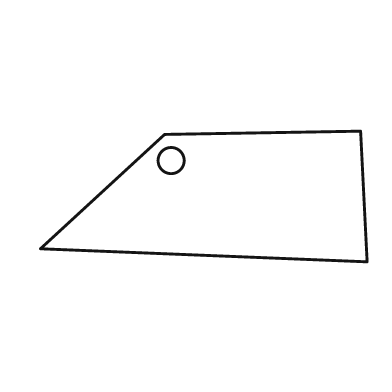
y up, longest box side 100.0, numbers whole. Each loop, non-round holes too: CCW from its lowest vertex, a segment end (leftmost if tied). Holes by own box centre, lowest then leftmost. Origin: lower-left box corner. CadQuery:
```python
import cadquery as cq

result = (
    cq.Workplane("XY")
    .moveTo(100.0, 0.0)
    .lineTo(98.0, 40.0)
    .lineTo(38.0, 39.0)
    .lineTo(0.0, 4.0)
    .close()
    .moveTo(40.0, 31.0)
    .circle(4.0)
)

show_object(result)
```